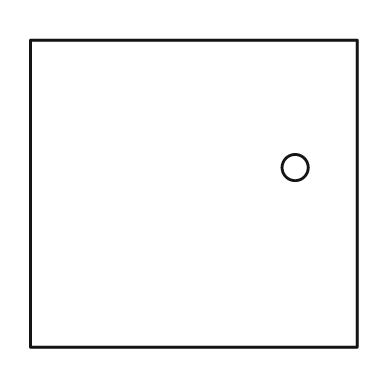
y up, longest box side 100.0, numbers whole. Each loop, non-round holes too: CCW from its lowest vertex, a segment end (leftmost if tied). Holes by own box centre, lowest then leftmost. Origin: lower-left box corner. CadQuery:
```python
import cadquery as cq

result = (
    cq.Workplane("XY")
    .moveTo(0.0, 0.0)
    .lineTo(100.0, 0.0)
    .lineTo(100.0, 94.0)
    .lineTo(0.0, 94.0)
    .close()
    .moveTo(81.0, 55.0)
    .circle(4.0)
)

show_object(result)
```